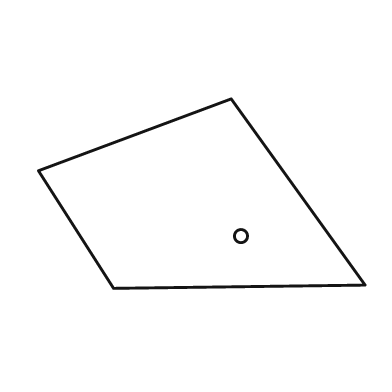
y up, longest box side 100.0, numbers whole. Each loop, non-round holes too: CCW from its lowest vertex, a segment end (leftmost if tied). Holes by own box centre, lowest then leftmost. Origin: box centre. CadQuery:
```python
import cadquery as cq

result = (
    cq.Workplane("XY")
    .moveTo(-27.0, -29.0)
    .lineTo(50.0, -28.0)
    .lineTo(9.0, 29.0)
    .lineTo(-50.0, 7.0)
    .close()
    .moveTo(12.0, -13.0)
    .circle(2.0)
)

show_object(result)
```